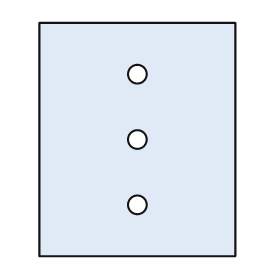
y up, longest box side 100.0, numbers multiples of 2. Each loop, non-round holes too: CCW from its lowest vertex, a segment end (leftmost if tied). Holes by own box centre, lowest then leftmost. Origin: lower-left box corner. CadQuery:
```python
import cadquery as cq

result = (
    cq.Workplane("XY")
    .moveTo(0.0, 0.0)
    .lineTo(84.0, 0.0)
    .lineTo(84.0, 100.0)
    .lineTo(0.0, 100.0)
    .close()
    .moveTo(42.0, 22.0)
    .circle(4.0)
    .moveTo(42.0, 50.0)
    .circle(4.0)
    .moveTo(42.0, 78.0)
    .circle(4.0)
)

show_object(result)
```